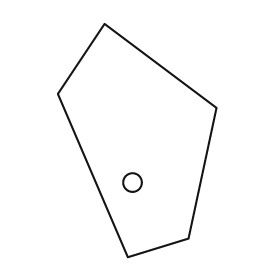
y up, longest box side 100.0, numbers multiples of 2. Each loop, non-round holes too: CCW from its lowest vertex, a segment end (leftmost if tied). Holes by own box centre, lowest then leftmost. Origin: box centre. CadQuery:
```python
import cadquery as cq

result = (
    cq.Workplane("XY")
    .moveTo(-4.0, -50.0)
    .lineTo(22.0, -42.0)
    .lineTo(34.0, 14.0)
    .lineTo(-14.0, 50.0)
    .lineTo(-34.0, 20.0)
    .close()
    .moveTo(-2.0, -18.0)
    .circle(4.0)
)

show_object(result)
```